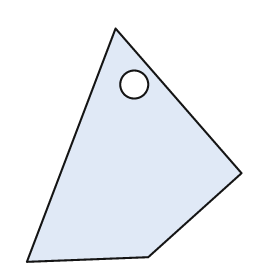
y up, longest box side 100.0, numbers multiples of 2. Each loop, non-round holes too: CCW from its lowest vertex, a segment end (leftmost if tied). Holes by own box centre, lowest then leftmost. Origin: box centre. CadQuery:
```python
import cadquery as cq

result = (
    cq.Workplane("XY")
    .moveTo(-46.0, -50.0)
    .lineTo(6.0, -48.0)
    .lineTo(46.0, -12.0)
    .lineTo(-8.0, 50.0)
    .close()
    .moveTo(0.0, 26.0)
    .circle(6.0)
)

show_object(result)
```